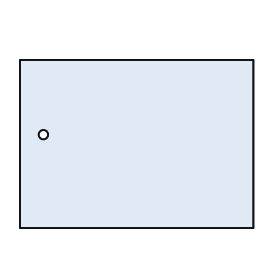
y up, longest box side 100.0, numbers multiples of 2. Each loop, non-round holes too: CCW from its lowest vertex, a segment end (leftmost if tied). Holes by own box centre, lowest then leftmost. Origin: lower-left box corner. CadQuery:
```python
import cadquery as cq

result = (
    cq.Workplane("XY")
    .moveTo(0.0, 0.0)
    .lineTo(100.0, 0.0)
    .lineTo(100.0, 72.0)
    .lineTo(0.0, 72.0)
    .close()
    .moveTo(10.0, 40.0)
    .circle(2.0)
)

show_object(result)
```